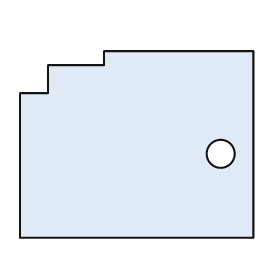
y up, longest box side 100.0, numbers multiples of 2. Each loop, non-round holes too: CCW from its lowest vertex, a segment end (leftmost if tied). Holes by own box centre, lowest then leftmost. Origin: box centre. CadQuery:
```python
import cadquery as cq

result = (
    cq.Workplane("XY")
    .moveTo(-50.0, -40.0)
    .lineTo(50.0, -40.0)
    .lineTo(50.0, 40.0)
    .lineTo(-14.0, 40.0)
    .lineTo(-14.0, 34.0)
    .lineTo(-38.0, 34.0)
    .lineTo(-38.0, 22.0)
    .lineTo(-50.0, 22.0)
    .close()
    .moveTo(36.0, -4.0)
    .circle(6.0)
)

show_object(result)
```